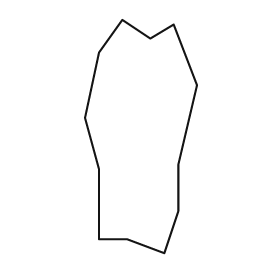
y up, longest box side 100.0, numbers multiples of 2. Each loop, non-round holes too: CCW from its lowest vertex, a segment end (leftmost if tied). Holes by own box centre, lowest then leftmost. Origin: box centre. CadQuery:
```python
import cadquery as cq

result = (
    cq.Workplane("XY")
    .moveTo(10.0, -50.0)
    .lineTo(16.0, -32.0)
    .lineTo(16.0, -12.0)
    .lineTo(24.0, 22.0)
    .lineTo(14.0, 48.0)
    .lineTo(4.0, 42.0)
    .lineTo(-8.0, 50.0)
    .lineTo(-18.0, 36.0)
    .lineTo(-24.0, 8.0)
    .lineTo(-18.0, -14.0)
    .lineTo(-18.0, -44.0)
    .lineTo(-6.0, -44.0)
    .close()
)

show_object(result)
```